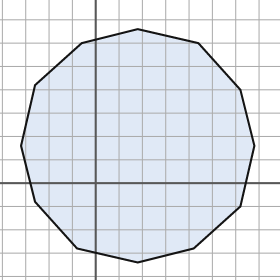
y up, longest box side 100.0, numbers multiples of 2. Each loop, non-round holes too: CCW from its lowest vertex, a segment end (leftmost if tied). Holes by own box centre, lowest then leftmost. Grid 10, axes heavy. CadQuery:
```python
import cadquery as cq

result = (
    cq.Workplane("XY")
    .moveTo(18.0, -34.0)
    .lineTo(42.0, -28.0)
    .lineTo(62.0, -10.0)
    .lineTo(68.0, 16.0)
    .lineTo(62.0, 40.0)
    .lineTo(44.0, 60.0)
    .lineTo(18.0, 66.0)
    .lineTo(-6.0, 60.0)
    .lineTo(-26.0, 42.0)
    .lineTo(-32.0, 16.0)
    .lineTo(-26.0, -8.0)
    .lineTo(-8.0, -28.0)
    .close()
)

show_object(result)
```